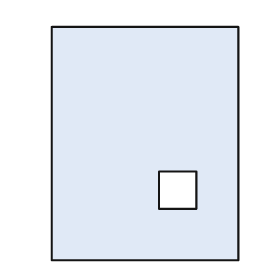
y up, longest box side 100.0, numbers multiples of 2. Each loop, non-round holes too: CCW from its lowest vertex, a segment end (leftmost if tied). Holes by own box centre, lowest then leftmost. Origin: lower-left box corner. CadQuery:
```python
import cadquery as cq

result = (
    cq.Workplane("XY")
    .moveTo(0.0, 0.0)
    .lineTo(80.0, 0.0)
    .lineTo(80.0, 100.0)
    .lineTo(0.0, 100.0)
    .close()
    .moveTo(46.0, 22.0)
    .lineTo(62.0, 22.0)
    .lineTo(62.0, 38.0)
    .lineTo(46.0, 38.0)
    .close()
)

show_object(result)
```